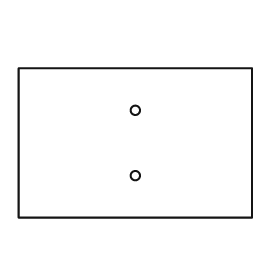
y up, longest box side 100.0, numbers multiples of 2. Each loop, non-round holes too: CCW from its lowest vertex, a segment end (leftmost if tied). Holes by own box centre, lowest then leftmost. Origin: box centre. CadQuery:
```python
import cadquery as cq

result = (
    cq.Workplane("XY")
    .moveTo(-50.0, -32.0)
    .lineTo(50.0, -32.0)
    .lineTo(50.0, 32.0)
    .lineTo(-50.0, 32.0)
    .close()
    .moveTo(0.0, -14.0)
    .circle(2.0)
    .moveTo(0.0, 14.0)
    .circle(2.0)
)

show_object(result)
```